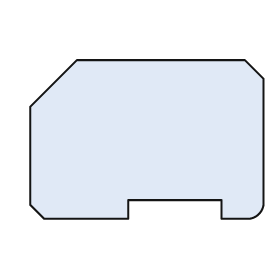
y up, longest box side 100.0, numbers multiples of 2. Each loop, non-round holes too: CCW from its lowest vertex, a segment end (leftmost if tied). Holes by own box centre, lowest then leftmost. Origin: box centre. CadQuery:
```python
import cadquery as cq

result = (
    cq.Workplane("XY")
    .moveTo(-44.0, -34.0)
    .lineTo(-8.0, -34.0)
    .lineTo(-8.0, -26.0)
    .lineTo(32.0, -26.0)
    .lineTo(32.0, -34.0)
    .lineTo(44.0, -34.0)
    .threePointArc((48.0, -32.0), (50.0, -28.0))
    .lineTo(50.0, 26.0)
    .lineTo(42.0, 34.0)
    .lineTo(-30.0, 34.0)
    .lineTo(-50.0, 14.0)
    .lineTo(-50.0, -28.0)
    .close()
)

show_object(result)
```